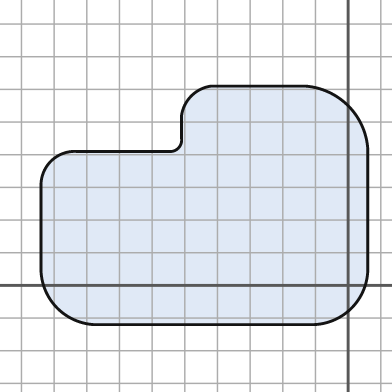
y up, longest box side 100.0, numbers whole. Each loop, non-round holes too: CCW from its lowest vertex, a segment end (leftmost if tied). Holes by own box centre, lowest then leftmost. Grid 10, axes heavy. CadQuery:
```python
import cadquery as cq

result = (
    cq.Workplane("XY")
    .moveTo(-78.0, -12.0)
    .lineTo(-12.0, -12.0)
    .threePointArc((1.0, -7.0), (6.0, 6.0))
    .lineTo(6.0, 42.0)
    .threePointArc((0.0, 55.0), (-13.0, 61.0))
    .lineTo(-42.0, 61.0)
    .threePointArc((-48.0, 58.0), (-51.0, 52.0))
    .lineTo(-51.0, 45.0)
    .threePointArc((-52.0, 42.0), (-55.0, 41.0))
    .lineTo(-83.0, 41.0)
    .threePointArc((-91.0, 38.0), (-94.0, 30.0))
    .lineTo(-94.0, 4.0)
    .threePointArc((-89.0, -7.0), (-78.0, -12.0))
    .close()
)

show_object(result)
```